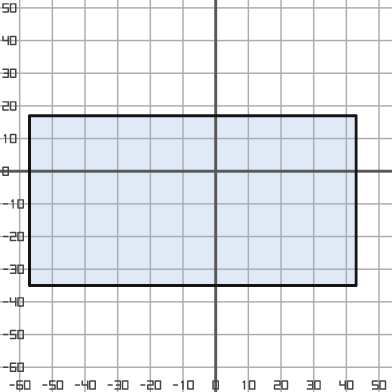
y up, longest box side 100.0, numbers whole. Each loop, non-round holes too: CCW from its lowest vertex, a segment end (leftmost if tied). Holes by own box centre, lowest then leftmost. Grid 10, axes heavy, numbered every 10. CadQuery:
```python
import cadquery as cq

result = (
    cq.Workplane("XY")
    .moveTo(-57.0, -35.0)
    .lineTo(43.0, -35.0)
    .lineTo(43.0, 17.0)
    .lineTo(-57.0, 17.0)
    .close()
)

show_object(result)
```